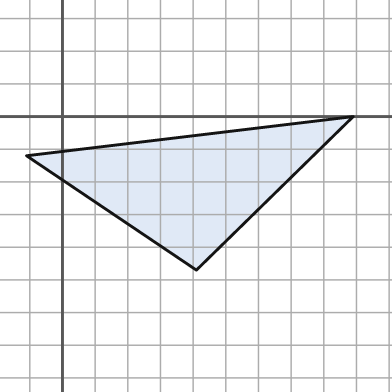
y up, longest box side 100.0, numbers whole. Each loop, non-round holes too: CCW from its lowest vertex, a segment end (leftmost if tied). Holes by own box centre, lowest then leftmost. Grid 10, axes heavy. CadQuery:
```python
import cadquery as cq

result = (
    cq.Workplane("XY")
    .moveTo(41.0, -47.0)
    .lineTo(89.0, 0.0)
    .lineTo(-11.0, -12.0)
    .close()
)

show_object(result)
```